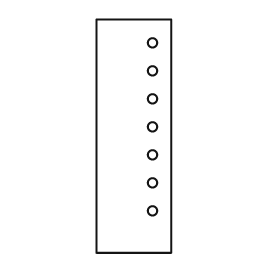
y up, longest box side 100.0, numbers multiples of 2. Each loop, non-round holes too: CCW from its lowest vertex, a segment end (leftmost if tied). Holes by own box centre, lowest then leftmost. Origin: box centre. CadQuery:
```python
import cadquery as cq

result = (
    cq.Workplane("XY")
    .moveTo(-16.0, -50.0)
    .lineTo(16.0, -50.0)
    .lineTo(16.0, 50.0)
    .lineTo(-16.0, 50.0)
    .close()
    .moveTo(8.0, -32.0)
    .circle(2.0)
    .moveTo(8.0, -20.0)
    .circle(2.0)
    .moveTo(8.0, -8.0)
    .circle(2.0)
    .moveTo(8.0, 4.0)
    .circle(2.0)
    .moveTo(8.0, 16.0)
    .circle(2.0)
    .moveTo(8.0, 28.0)
    .circle(2.0)
    .moveTo(8.0, 40.0)
    .circle(2.0)
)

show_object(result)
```